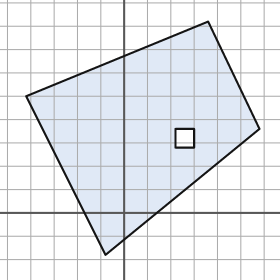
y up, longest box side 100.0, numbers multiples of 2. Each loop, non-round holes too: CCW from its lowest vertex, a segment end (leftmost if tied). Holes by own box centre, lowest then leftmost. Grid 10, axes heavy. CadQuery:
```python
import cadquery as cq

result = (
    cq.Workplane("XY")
    .moveTo(-8.0, -18.0)
    .lineTo(58.0, 36.0)
    .lineTo(36.0, 82.0)
    .lineTo(-42.0, 50.0)
    .close()
    .moveTo(22.0, 28.0)
    .lineTo(30.0, 28.0)
    .lineTo(30.0, 36.0)
    .lineTo(22.0, 36.0)
    .close()
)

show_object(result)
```